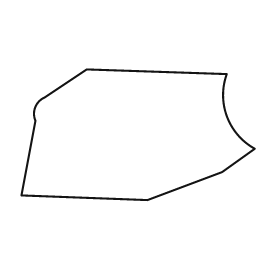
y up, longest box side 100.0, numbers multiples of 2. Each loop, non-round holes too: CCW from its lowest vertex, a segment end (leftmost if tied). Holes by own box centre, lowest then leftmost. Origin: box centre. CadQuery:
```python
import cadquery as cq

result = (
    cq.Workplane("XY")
    .moveTo(4.0, -28.0)
    .lineTo(36.0, -16.0)
    .lineTo(50.0, -6.0)
    .threePointArc((38.0, 8.0), (38.0, 26.0))
    .lineTo(-22.0, 28.0)
    .lineTo(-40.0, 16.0)
    .threePointArc((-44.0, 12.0), (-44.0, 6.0))
    .lineTo(-50.0, -26.0)
    .close()
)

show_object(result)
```